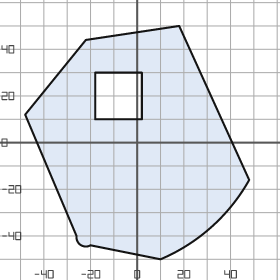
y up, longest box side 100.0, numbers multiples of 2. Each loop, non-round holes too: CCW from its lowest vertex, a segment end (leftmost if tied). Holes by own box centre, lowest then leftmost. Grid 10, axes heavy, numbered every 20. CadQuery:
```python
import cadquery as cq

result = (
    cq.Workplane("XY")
    .moveTo(10.0, -50.0)
    .threePointArc((32.0, -36.0), (48.0, -16.0))
    .lineTo(18.0, 50.0)
    .lineTo(-22.0, 44.0)
    .lineTo(-48.0, 12.0)
    .lineTo(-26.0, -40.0)
    .threePointArc((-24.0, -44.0), (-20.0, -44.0))
    .close()
    .moveTo(-18.0, 10.0)
    .lineTo(2.0, 10.0)
    .lineTo(2.0, 30.0)
    .lineTo(-18.0, 30.0)
    .close()
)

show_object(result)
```